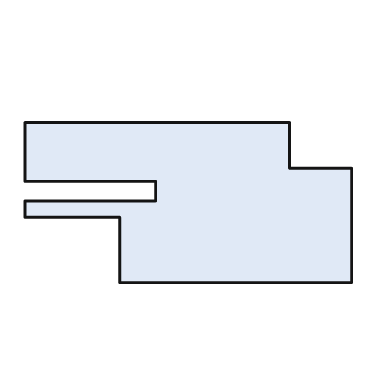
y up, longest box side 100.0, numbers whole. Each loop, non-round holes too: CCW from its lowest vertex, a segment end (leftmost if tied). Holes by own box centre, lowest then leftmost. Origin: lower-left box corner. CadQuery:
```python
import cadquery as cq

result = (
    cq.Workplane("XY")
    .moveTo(29.0, 0.0)
    .lineTo(100.0, 0.0)
    .lineTo(100.0, 35.0)
    .lineTo(81.0, 35.0)
    .lineTo(81.0, 49.0)
    .lineTo(0.0, 49.0)
    .lineTo(0.0, 31.0)
    .lineTo(40.0, 31.0)
    .lineTo(40.0, 25.0)
    .lineTo(0.0, 25.0)
    .lineTo(0.0, 20.0)
    .lineTo(29.0, 20.0)
    .close()
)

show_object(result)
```